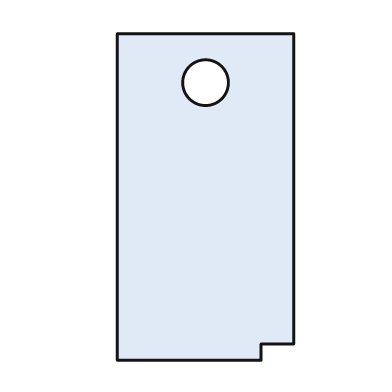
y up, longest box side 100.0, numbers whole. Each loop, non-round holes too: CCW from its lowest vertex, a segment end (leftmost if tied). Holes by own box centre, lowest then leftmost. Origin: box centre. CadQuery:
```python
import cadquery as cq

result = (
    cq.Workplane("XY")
    .moveTo(-27.0, -50.0)
    .lineTo(17.0, -50.0)
    .lineTo(17.0, -45.0)
    .lineTo(27.0, -45.0)
    .lineTo(27.0, 50.0)
    .lineTo(-27.0, 50.0)
    .close()
    .moveTo(0.0, 35.0)
    .circle(7.0)
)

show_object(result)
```